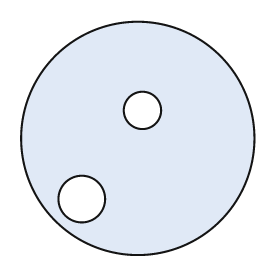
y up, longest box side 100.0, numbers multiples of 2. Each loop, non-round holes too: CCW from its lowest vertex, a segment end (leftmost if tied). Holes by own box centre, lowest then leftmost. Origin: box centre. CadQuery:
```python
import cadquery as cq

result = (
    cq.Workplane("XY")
    .moveTo(0.0, 0.0)
    .circle(50.0)
    .moveTo(-24.0, -26.0)
    .circle(10.0)
    .moveTo(2.0, 12.0)
    .circle(8.0)
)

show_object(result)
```